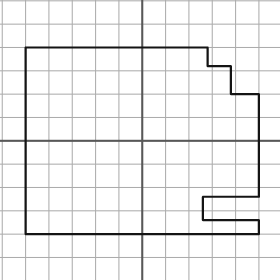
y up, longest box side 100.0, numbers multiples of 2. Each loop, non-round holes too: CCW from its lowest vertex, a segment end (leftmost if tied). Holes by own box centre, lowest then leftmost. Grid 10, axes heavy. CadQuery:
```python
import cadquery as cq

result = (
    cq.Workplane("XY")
    .moveTo(-50.0, -40.0)
    .lineTo(50.0, -40.0)
    .lineTo(50.0, -34.0)
    .lineTo(26.0, -34.0)
    .lineTo(26.0, -24.0)
    .lineTo(50.0, -24.0)
    .lineTo(50.0, 20.0)
    .lineTo(38.0, 20.0)
    .lineTo(38.0, 32.0)
    .lineTo(28.0, 32.0)
    .lineTo(28.0, 40.0)
    .lineTo(-50.0, 40.0)
    .close()
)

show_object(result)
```